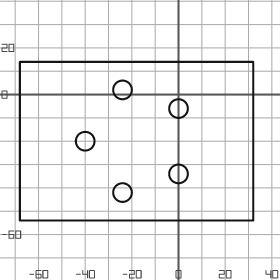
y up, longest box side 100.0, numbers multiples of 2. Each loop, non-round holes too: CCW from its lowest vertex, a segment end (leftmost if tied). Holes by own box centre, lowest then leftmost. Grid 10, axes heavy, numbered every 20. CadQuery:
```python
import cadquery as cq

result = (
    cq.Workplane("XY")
    .moveTo(-68.0, -54.0)
    .lineTo(32.0, -54.0)
    .lineTo(32.0, 14.0)
    .lineTo(-68.0, 14.0)
    .close()
    .moveTo(-24.0, -42.0)
    .circle(4.0)
    .moveTo(0.0, -34.0)
    .circle(4.0)
    .moveTo(-40.0, -20.0)
    .circle(4.0)
    .moveTo(0.0, -6.0)
    .circle(4.0)
    .moveTo(-24.0, 2.0)
    .circle(4.0)
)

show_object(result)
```